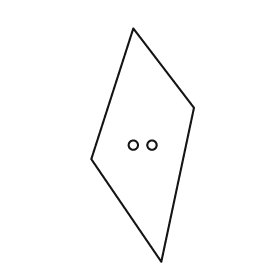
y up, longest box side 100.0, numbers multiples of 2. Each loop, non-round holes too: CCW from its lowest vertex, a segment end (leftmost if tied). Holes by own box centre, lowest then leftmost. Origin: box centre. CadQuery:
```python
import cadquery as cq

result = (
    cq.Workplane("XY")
    .moveTo(8.0, -50.0)
    .lineTo(22.0, 16.0)
    .lineTo(-4.0, 50.0)
    .lineTo(-22.0, -6.0)
    .close()
    .moveTo(-4.0, 0.0)
    .circle(2.0)
    .moveTo(4.0, 0.0)
    .circle(2.0)
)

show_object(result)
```